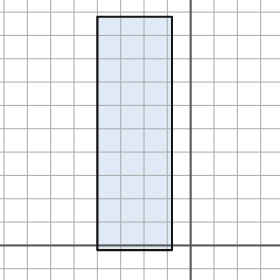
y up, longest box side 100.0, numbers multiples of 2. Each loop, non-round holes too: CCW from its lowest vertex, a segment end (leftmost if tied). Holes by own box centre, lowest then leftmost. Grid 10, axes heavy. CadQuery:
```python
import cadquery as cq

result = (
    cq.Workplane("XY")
    .moveTo(-40.0, -2.0)
    .lineTo(-8.0, -2.0)
    .lineTo(-8.0, 98.0)
    .lineTo(-40.0, 98.0)
    .close()
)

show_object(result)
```